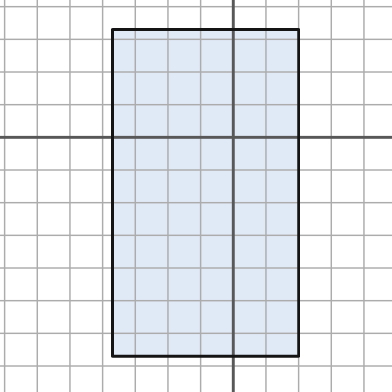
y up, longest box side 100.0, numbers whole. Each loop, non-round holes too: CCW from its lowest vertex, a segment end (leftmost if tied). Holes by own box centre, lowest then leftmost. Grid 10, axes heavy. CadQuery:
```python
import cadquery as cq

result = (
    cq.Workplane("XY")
    .moveTo(-37.0, -67.0)
    .lineTo(20.0, -67.0)
    .lineTo(20.0, 33.0)
    .lineTo(-37.0, 33.0)
    .close()
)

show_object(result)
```